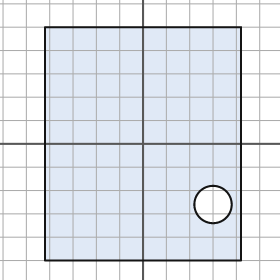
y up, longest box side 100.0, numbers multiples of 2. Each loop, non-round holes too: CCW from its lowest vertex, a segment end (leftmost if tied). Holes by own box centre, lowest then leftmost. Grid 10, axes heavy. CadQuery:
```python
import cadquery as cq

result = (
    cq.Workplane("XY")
    .moveTo(-42.0, -50.0)
    .lineTo(42.0, -50.0)
    .lineTo(42.0, 50.0)
    .lineTo(-42.0, 50.0)
    .close()
    .moveTo(30.0, -26.0)
    .circle(8.0)
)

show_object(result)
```